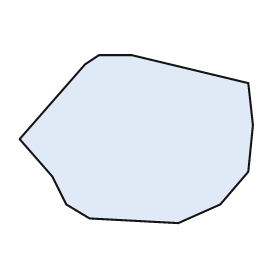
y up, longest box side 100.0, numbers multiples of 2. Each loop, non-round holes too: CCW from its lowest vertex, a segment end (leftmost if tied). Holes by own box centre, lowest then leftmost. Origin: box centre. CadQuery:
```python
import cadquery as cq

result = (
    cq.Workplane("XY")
    .moveTo(18.0, -36.0)
    .lineTo(36.0, -28.0)
    .lineTo(48.0, -14.0)
    .lineTo(50.0, 6.0)
    .lineTo(48.0, 24.0)
    .lineTo(-2.0, 36.0)
    .lineTo(-16.0, 36.0)
    .lineTo(-22.0, 32.0)
    .lineTo(-50.0, 0.0)
    .lineTo(-36.0, -16.0)
    .lineTo(-30.0, -28.0)
    .lineTo(-20.0, -34.0)
    .close()
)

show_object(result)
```